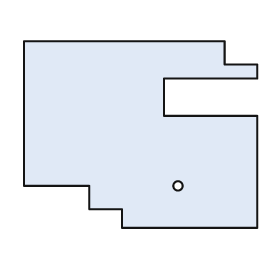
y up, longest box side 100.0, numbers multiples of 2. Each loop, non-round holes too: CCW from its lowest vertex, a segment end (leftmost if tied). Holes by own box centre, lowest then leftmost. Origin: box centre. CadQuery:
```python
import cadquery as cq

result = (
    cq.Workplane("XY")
    .moveTo(-8.0, -40.0)
    .lineTo(50.0, -40.0)
    .lineTo(50.0, 8.0)
    .lineTo(10.0, 8.0)
    .lineTo(10.0, 24.0)
    .lineTo(50.0, 24.0)
    .lineTo(50.0, 30.0)
    .lineTo(36.0, 30.0)
    .lineTo(36.0, 40.0)
    .lineTo(-50.0, 40.0)
    .lineTo(-50.0, -22.0)
    .lineTo(-22.0, -22.0)
    .lineTo(-22.0, -32.0)
    .lineTo(-8.0, -32.0)
    .close()
    .moveTo(16.0, -22.0)
    .circle(2.0)
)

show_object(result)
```